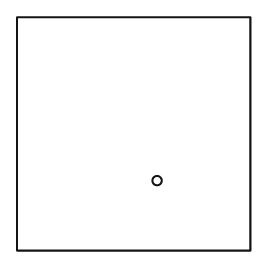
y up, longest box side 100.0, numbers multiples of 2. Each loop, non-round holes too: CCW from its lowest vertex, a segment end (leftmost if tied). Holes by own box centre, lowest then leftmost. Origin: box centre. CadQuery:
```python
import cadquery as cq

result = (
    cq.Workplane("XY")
    .moveTo(-50.0, -50.0)
    .lineTo(50.0, -50.0)
    .lineTo(50.0, 50.0)
    .lineTo(-50.0, 50.0)
    .close()
    .moveTo(10.0, -20.0)
    .circle(2.0)
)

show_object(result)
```